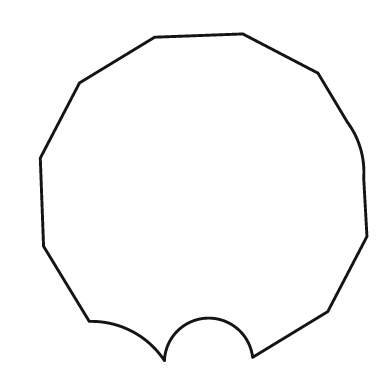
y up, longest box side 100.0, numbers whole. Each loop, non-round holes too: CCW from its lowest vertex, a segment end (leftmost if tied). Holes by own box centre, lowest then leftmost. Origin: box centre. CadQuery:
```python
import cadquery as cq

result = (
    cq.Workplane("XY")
    .moveTo(-12.0, -50.0)
    .threePointArc((1.0, -37.0), (15.0, -49.0))
    .lineTo(38.0, -35.0)
    .lineTo(50.0, -12.0)
    .lineTo(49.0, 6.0)
    .threePointArc((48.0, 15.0), (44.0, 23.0))
    .lineTo(35.0, 38.0)
    .lineTo(12.0, 50.0)
    .lineTo(-15.0, 49.0)
    .lineTo(-38.0, 35.0)
    .lineTo(-50.0, 12.0)
    .lineTo(-49.0, -15.0)
    .lineTo(-35.0, -38.0)
    .threePointArc((-22.0, -41.0), (-12.0, -50.0))
    .close()
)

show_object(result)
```